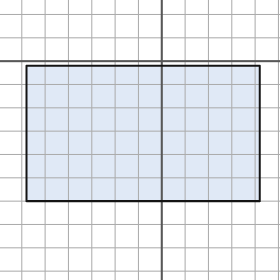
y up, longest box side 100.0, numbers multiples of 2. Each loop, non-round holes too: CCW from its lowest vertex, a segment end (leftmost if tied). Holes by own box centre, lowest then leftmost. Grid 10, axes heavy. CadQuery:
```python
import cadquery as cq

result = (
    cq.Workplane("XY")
    .moveTo(-58.0, -60.0)
    .lineTo(42.0, -60.0)
    .lineTo(42.0, -2.0)
    .lineTo(-58.0, -2.0)
    .close()
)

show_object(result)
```